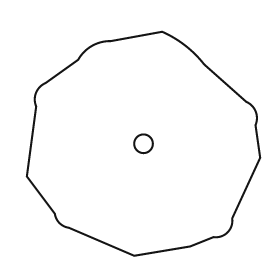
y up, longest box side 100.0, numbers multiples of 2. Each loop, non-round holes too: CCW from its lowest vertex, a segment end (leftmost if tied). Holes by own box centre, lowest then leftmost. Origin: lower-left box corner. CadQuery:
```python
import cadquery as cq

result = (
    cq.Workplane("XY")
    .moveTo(46.0, 0.0)
    .lineTo(70.0, 4.0)
    .lineTo(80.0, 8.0)
    .threePointArc((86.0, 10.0), (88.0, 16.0))
    .lineTo(100.0, 42.0)
    .lineTo(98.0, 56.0)
    .threePointArc((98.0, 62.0), (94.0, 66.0))
    .lineTo(76.0, 82.0)
    .threePointArc((68.0, 90.0), (58.0, 96.0))
    .lineTo(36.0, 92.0)
    .threePointArc((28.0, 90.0), (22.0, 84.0))
    .lineTo(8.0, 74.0)
    .threePointArc((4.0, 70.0), (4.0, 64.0))
    .lineTo(0.0, 34.0)
    .lineTo(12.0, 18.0)
    .threePointArc((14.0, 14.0), (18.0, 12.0))
    .close()
    .moveTo(50.0, 48.0)
    .circle(4.0)
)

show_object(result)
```